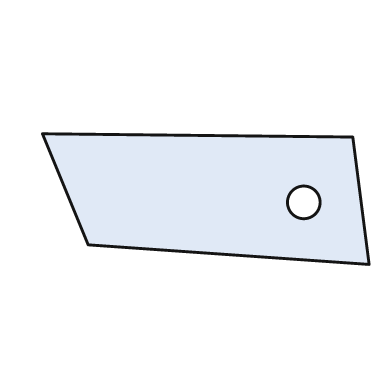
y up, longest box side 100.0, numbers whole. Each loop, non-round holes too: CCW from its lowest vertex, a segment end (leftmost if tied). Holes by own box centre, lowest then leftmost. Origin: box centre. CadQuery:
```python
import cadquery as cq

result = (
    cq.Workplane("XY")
    .moveTo(50.0, -20.0)
    .lineTo(45.0, 19.0)
    .lineTo(-50.0, 20.0)
    .lineTo(-36.0, -14.0)
    .close()
    .moveTo(30.0, -1.0)
    .circle(5.0)
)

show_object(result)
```